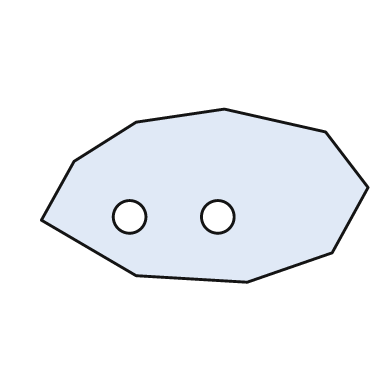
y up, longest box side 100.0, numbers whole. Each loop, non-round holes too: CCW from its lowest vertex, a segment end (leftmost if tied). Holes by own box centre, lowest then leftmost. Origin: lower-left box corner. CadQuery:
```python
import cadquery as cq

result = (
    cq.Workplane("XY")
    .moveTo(63.0, 0.0)
    .lineTo(89.0, 9.0)
    .lineTo(100.0, 29.0)
    .lineTo(87.0, 46.0)
    .lineTo(56.0, 53.0)
    .lineTo(29.0, 49.0)
    .lineTo(10.0, 37.0)
    .lineTo(0.0, 19.0)
    .lineTo(29.0, 2.0)
    .close()
    .moveTo(27.0, 20.0)
    .circle(5.0)
    .moveTo(54.0, 20.0)
    .circle(5.0)
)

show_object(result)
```